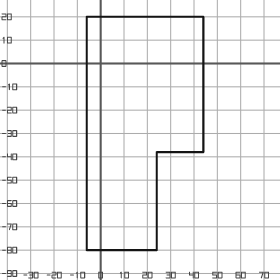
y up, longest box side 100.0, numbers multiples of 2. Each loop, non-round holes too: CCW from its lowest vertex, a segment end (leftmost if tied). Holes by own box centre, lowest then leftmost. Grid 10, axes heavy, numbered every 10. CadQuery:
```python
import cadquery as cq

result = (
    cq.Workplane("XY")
    .moveTo(-6.0, -80.0)
    .lineTo(24.0, -80.0)
    .lineTo(24.0, -38.0)
    .lineTo(44.0, -38.0)
    .lineTo(44.0, 20.0)
    .lineTo(-6.0, 20.0)
    .close()
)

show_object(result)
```